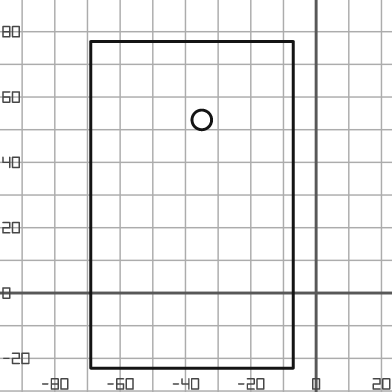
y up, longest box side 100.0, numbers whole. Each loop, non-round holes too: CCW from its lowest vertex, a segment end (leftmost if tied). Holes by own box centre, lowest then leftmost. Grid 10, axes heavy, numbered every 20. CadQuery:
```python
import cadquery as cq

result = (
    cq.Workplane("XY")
    .moveTo(-69.0, -23.0)
    .lineTo(-7.0, -23.0)
    .lineTo(-7.0, 77.0)
    .lineTo(-69.0, 77.0)
    .close()
    .moveTo(-35.0, 53.0)
    .circle(3.0)
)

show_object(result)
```